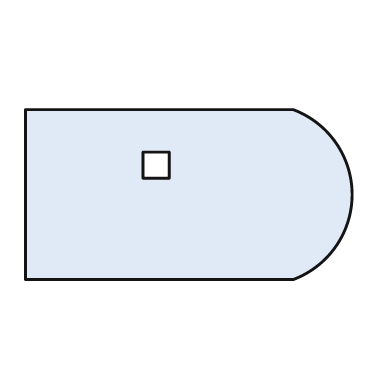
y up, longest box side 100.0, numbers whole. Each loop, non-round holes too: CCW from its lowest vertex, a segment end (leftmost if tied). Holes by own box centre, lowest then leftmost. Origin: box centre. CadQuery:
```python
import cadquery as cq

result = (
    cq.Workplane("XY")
    .moveTo(-50.0, -26.0)
    .lineTo(32.0, -26.0)
    .threePointArc((50.0, 0.0), (32.0, 26.0))
    .lineTo(-50.0, 26.0)
    .close()
    .moveTo(-14.0, 5.0)
    .lineTo(-6.0, 5.0)
    .lineTo(-6.0, 13.0)
    .lineTo(-14.0, 13.0)
    .close()
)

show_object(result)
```